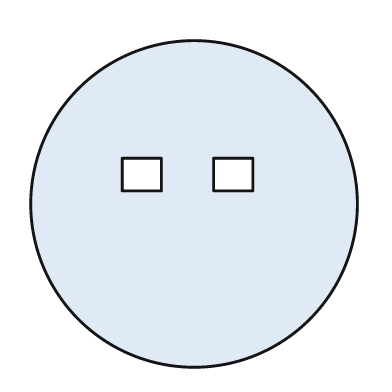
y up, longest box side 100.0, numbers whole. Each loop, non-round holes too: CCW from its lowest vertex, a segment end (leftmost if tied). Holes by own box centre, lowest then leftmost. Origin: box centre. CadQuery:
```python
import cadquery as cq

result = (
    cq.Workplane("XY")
    .moveTo(0.0, 0.0)
    .circle(50.0)
    .moveTo(-22.0, 4.0)
    .lineTo(-10.0, 4.0)
    .lineTo(-10.0, 14.0)
    .lineTo(-22.0, 14.0)
    .close()
    .moveTo(6.0, 4.0)
    .lineTo(18.0, 4.0)
    .lineTo(18.0, 14.0)
    .lineTo(6.0, 14.0)
    .close()
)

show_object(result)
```